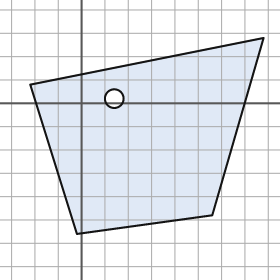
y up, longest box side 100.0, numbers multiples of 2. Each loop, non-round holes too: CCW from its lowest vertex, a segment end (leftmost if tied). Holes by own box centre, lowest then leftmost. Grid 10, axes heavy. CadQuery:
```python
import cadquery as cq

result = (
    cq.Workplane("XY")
    .moveTo(-2.0, -56.0)
    .lineTo(56.0, -48.0)
    .lineTo(78.0, 28.0)
    .lineTo(-22.0, 8.0)
    .close()
    .moveTo(14.0, 2.0)
    .circle(4.0)
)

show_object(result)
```